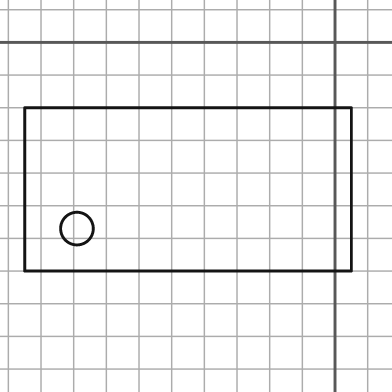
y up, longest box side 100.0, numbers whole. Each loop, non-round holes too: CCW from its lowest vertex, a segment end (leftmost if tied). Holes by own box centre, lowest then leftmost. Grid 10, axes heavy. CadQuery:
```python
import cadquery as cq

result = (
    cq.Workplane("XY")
    .moveTo(-95.0, -70.0)
    .lineTo(5.0, -70.0)
    .lineTo(5.0, -20.0)
    .lineTo(-95.0, -20.0)
    .close()
    .moveTo(-79.0, -57.0)
    .circle(5.0)
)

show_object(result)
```